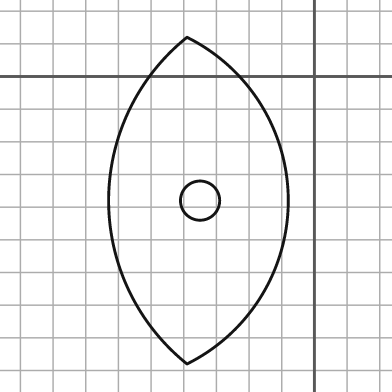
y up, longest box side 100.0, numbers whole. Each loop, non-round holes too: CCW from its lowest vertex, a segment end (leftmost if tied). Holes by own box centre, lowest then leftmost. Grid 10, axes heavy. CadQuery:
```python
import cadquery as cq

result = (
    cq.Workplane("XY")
    .moveTo(-39.0, -88.0)
    .threePointArc((-8.0, -38.0), (-39.0, 12.0))
    .threePointArc((-63.0, -38.0), (-39.0, -88.0))
    .close()
    .moveTo(-35.0, -38.0)
    .circle(6.0)
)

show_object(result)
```